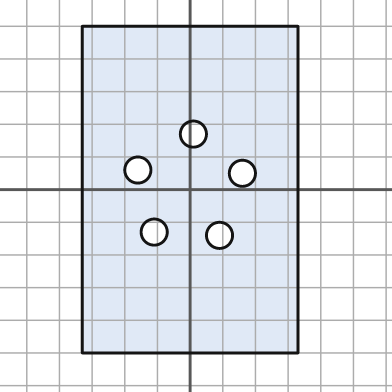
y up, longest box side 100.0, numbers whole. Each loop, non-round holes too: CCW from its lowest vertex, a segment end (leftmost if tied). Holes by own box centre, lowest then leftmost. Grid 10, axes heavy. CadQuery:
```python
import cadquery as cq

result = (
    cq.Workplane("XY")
    .moveTo(-33.0, -50.0)
    .lineTo(33.0, -50.0)
    .lineTo(33.0, 50.0)
    .lineTo(-33.0, 50.0)
    .close()
    .moveTo(9.0, -14.0)
    .circle(4.0)
    .moveTo(-11.0, -13.0)
    .circle(4.0)
    .moveTo(16.0, 5.0)
    .circle(4.0)
    .moveTo(-16.0, 6.0)
    .circle(4.0)
    .moveTo(1.0, 17.0)
    .circle(4.0)
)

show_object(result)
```